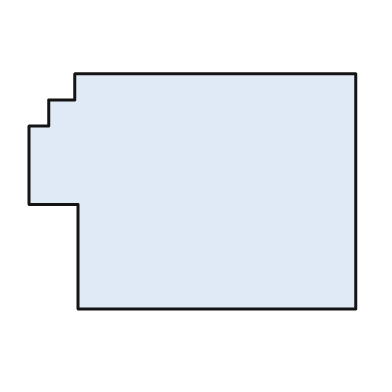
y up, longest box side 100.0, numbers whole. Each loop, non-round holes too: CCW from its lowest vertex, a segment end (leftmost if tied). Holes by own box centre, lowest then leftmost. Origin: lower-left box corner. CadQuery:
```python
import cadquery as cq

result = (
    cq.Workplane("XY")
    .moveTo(15.0, 0.0)
    .lineTo(100.0, 0.0)
    .lineTo(100.0, 72.0)
    .lineTo(14.0, 72.0)
    .lineTo(14.0, 64.0)
    .lineTo(6.0, 64.0)
    .lineTo(6.0, 56.0)
    .lineTo(0.0, 56.0)
    .lineTo(0.0, 32.0)
    .lineTo(15.0, 32.0)
    .close()
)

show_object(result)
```